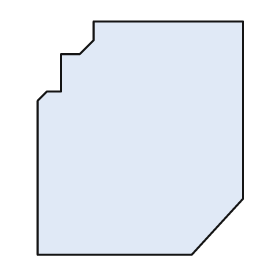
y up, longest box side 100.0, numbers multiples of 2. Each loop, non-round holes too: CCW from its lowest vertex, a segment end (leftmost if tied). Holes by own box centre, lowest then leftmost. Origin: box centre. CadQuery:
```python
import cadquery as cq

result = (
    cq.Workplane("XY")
    .moveTo(-44.0, -50.0)
    .lineTo(22.0, -50.0)
    .lineTo(44.0, -26.0)
    .lineTo(44.0, 50.0)
    .lineTo(-20.0, 50.0)
    .lineTo(-20.0, 42.0)
    .lineTo(-26.0, 36.0)
    .lineTo(-34.0, 36.0)
    .lineTo(-34.0, 20.0)
    .lineTo(-40.0, 20.0)
    .lineTo(-44.0, 16.0)
    .close()
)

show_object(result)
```